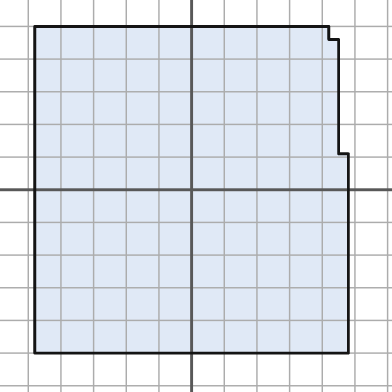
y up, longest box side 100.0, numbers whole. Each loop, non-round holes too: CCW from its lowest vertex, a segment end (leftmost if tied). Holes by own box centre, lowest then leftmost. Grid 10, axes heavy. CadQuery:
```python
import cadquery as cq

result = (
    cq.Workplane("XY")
    .moveTo(-48.0, -50.0)
    .lineTo(48.0, -50.0)
    .lineTo(48.0, 11.0)
    .lineTo(45.0, 11.0)
    .lineTo(45.0, 46.0)
    .lineTo(42.0, 46.0)
    .lineTo(42.0, 50.0)
    .lineTo(-48.0, 50.0)
    .close()
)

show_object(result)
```